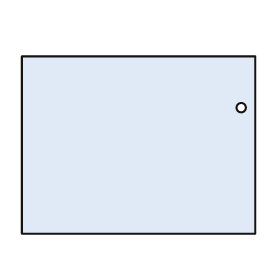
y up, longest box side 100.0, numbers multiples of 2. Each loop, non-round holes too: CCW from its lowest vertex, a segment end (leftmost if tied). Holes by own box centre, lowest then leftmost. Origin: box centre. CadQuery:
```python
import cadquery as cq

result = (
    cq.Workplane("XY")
    .moveTo(-50.0, -38.0)
    .lineTo(50.0, -38.0)
    .lineTo(50.0, 38.0)
    .lineTo(-50.0, 38.0)
    .close()
    .moveTo(44.0, 16.0)
    .circle(2.0)
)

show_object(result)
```